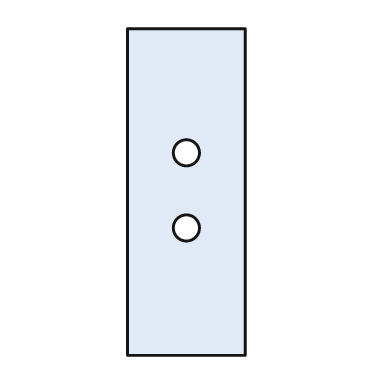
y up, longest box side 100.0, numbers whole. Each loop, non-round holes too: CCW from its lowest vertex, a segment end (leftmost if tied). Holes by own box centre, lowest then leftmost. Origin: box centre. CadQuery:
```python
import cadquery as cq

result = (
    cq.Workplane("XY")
    .moveTo(-18.0, -50.0)
    .lineTo(18.0, -50.0)
    .lineTo(18.0, 50.0)
    .lineTo(-18.0, 50.0)
    .close()
    .moveTo(0.0, -11.0)
    .circle(4.0)
    .moveTo(0.0, 12.0)
    .circle(4.0)
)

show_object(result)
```